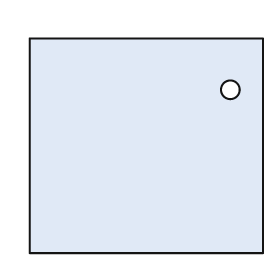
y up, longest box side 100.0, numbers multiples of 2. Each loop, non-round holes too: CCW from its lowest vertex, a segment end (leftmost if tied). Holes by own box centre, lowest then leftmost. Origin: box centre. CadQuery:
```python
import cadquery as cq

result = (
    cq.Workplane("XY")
    .moveTo(-50.0, -46.0)
    .lineTo(50.0, -46.0)
    .lineTo(50.0, 46.0)
    .lineTo(-50.0, 46.0)
    .close()
    .moveTo(36.0, 24.0)
    .circle(4.0)
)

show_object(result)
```